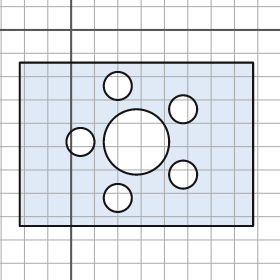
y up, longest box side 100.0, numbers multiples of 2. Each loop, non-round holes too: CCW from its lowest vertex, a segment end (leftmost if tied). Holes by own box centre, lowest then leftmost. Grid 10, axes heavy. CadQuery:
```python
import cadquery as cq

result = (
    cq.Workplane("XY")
    .moveTo(-22.0, -84.0)
    .lineTo(78.0, -84.0)
    .lineTo(78.0, -14.0)
    .lineTo(-22.0, -14.0)
    .close()
    .moveTo(20.0, -72.0)
    .circle(6.0)
    .moveTo(48.0, -62.0)
    .circle(6.0)
    .moveTo(4.0, -48.0)
    .circle(6.0)
    .moveTo(28.0, -48.0)
    .circle(14.0)
    .moveTo(48.0, -34.0)
    .circle(6.0)
    .moveTo(20.0, -24.0)
    .circle(6.0)
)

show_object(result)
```